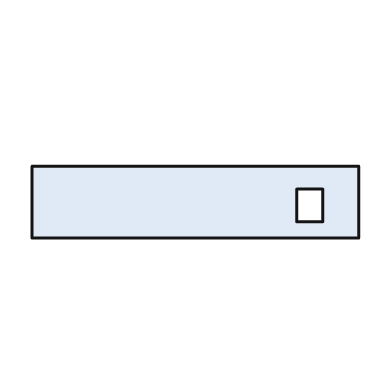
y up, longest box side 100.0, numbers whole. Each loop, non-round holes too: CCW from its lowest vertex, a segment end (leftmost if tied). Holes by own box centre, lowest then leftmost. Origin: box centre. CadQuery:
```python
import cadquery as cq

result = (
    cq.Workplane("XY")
    .moveTo(-50.0, -11.0)
    .lineTo(50.0, -11.0)
    .lineTo(50.0, 11.0)
    .lineTo(-50.0, 11.0)
    .close()
    .moveTo(31.0, -6.0)
    .lineTo(39.0, -6.0)
    .lineTo(39.0, 4.0)
    .lineTo(31.0, 4.0)
    .close()
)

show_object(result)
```